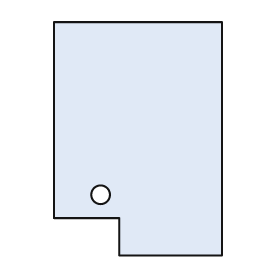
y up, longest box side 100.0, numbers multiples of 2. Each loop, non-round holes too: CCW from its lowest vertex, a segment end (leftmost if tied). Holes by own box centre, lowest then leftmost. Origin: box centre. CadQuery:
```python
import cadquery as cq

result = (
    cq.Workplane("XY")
    .moveTo(-8.0, -50.0)
    .lineTo(36.0, -50.0)
    .lineTo(36.0, 50.0)
    .lineTo(-36.0, 50.0)
    .lineTo(-36.0, -34.0)
    .lineTo(-8.0, -34.0)
    .close()
    .moveTo(-16.0, -24.0)
    .circle(4.0)
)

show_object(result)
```